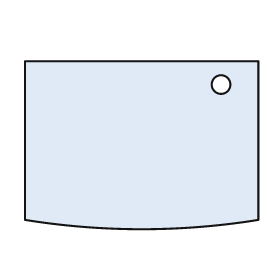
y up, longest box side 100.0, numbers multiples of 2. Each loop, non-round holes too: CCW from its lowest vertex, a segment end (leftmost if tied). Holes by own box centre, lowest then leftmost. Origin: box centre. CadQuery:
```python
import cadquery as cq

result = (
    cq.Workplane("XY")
    .moveTo(-50.0, -32.0)
    .threePointArc((0.0, -36.0), (50.0, -32.0))
    .lineTo(50.0, 36.0)
    .lineTo(-50.0, 36.0)
    .close()
    .moveTo(34.0, 26.0)
    .circle(4.0)
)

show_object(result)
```